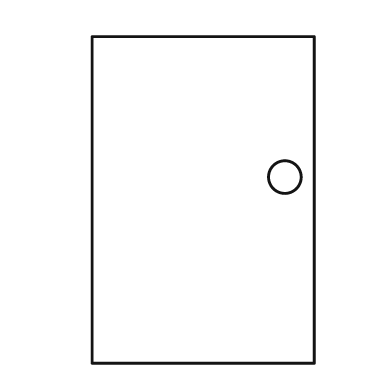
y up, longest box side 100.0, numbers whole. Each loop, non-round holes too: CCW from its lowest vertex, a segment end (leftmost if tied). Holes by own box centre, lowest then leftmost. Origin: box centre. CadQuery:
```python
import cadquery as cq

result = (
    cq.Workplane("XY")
    .moveTo(-34.0, -50.0)
    .lineTo(34.0, -50.0)
    .lineTo(34.0, 50.0)
    .lineTo(-34.0, 50.0)
    .close()
    .moveTo(25.0, 7.0)
    .circle(5.0)
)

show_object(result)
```